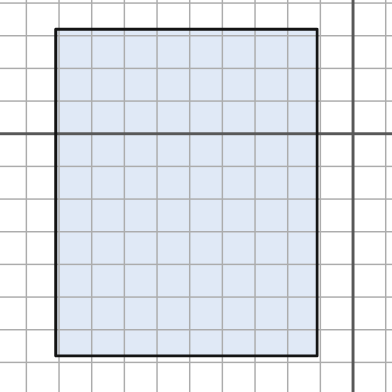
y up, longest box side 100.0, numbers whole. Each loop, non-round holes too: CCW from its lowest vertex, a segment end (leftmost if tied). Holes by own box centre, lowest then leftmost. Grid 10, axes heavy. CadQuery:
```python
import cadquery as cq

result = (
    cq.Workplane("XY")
    .moveTo(-91.0, -68.0)
    .lineTo(-11.0, -68.0)
    .lineTo(-11.0, 32.0)
    .lineTo(-91.0, 32.0)
    .close()
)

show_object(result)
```